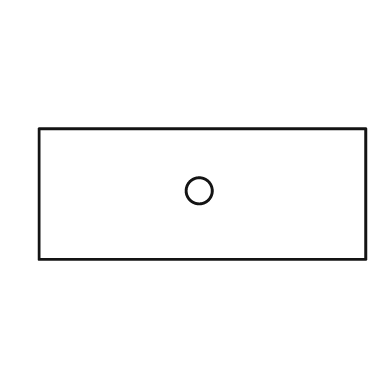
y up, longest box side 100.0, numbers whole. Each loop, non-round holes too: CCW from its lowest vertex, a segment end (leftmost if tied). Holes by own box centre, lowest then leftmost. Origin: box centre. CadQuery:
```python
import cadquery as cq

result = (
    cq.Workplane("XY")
    .moveTo(-50.0, -20.0)
    .lineTo(50.0, -20.0)
    .lineTo(50.0, 20.0)
    .lineTo(-50.0, 20.0)
    .close()
    .moveTo(-1.0, 1.0)
    .circle(4.0)
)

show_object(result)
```